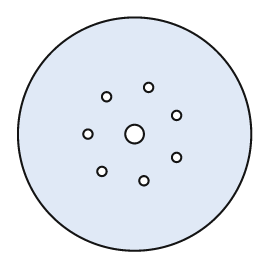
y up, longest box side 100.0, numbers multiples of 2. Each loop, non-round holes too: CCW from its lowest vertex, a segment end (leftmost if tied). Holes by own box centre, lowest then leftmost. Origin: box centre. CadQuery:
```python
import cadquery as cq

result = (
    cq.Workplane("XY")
    .moveTo(0.0, 0.0)
    .circle(50.0)
    .moveTo(4.0, -20.0)
    .circle(2.0)
    .moveTo(-14.0, -16.0)
    .circle(2.0)
    .moveTo(18.0, -10.0)
    .circle(2.0)
    .moveTo(-20.0, 0.0)
    .circle(2.0)
    .moveTo(0.0, 0.0)
    .circle(4.0)
    .moveTo(18.0, 8.0)
    .circle(2.0)
    .moveTo(-12.0, 16.0)
    .circle(2.0)
    .moveTo(6.0, 20.0)
    .circle(2.0)
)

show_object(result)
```